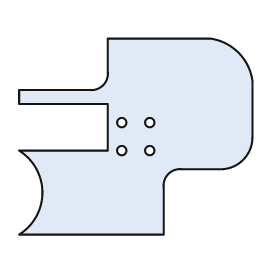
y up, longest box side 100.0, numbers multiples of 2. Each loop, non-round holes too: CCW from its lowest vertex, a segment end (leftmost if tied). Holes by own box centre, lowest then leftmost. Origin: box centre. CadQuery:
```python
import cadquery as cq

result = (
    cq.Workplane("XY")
    .moveTo(-50.0, -42.0)
    .lineTo(12.0, -42.0)
    .lineTo(12.0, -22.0)
    .threePointArc((14.0, -16.0), (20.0, -14.0))
    .lineTo(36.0, -14.0)
    .threePointArc((46.0, -10.0), (50.0, 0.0))
    .lineTo(50.0, 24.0)
    .threePointArc((44.0, 36.0), (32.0, 42.0))
    .lineTo(-12.0, 42.0)
    .lineTo(-12.0, 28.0)
    .threePointArc((-14.0, 22.0), (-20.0, 20.0))
    .lineTo(-50.0, 20.0)
    .lineTo(-50.0, 14.0)
    .lineTo(-12.0, 14.0)
    .lineTo(-12.0, -6.0)
    .lineTo(-50.0, -6.0)
    .threePointArc((-40.0, -24.0), (-50.0, -42.0))
    .close()
    .moveTo(-6.0, -6.0)
    .circle(2.0)
    .moveTo(6.0, -6.0)
    .circle(2.0)
    .moveTo(-6.0, 6.0)
    .circle(2.0)
    .moveTo(6.0, 6.0)
    .circle(2.0)
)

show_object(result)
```